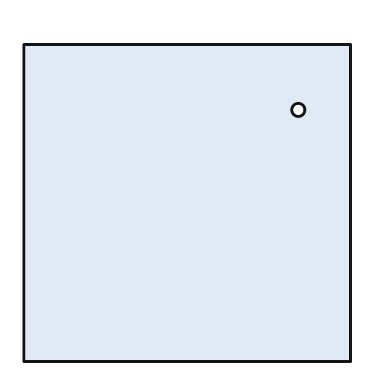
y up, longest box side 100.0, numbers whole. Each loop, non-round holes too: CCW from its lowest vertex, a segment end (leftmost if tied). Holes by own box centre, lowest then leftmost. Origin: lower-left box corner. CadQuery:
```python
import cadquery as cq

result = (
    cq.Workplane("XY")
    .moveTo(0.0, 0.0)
    .lineTo(100.0, 0.0)
    .lineTo(100.0, 97.0)
    .lineTo(0.0, 97.0)
    .close()
    .moveTo(84.0, 77.0)
    .circle(2.0)
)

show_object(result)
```